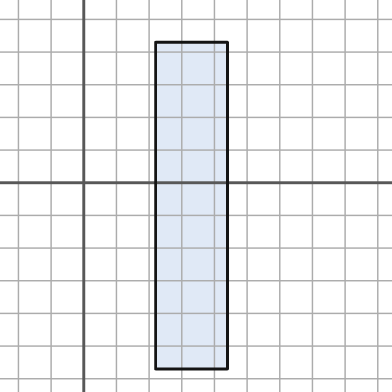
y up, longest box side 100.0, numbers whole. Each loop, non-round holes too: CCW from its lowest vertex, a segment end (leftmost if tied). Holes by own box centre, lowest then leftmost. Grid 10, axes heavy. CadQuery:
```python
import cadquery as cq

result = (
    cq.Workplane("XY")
    .moveTo(22.0, -57.0)
    .lineTo(44.0, -57.0)
    .lineTo(44.0, 43.0)
    .lineTo(22.0, 43.0)
    .close()
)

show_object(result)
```